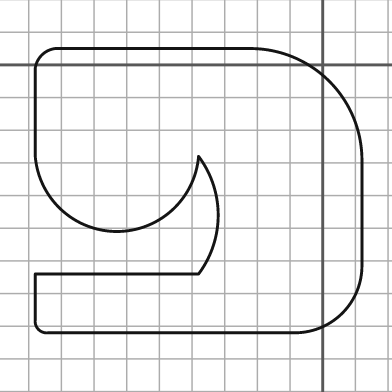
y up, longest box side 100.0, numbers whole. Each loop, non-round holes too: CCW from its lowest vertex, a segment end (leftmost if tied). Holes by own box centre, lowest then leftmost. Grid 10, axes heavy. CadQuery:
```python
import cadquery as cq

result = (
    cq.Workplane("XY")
    .moveTo(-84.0, -82.0)
    .lineTo(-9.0, -82.0)
    .threePointArc((6.0, -76.0), (12.0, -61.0))
    .lineTo(12.0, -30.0)
    .threePointArc((2.0, -5.0), (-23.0, 5.0))
    .lineTo(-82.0, 5.0)
    .threePointArc((-86.0, 3.0), (-88.0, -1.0))
    .lineTo(-88.0, -28.0)
    .threePointArc((-63.0, -51.0), (-38.0, -28.0))
    .threePointArc((-32.0, -46.0), (-38.0, -64.0))
    .lineTo(-88.0, -64.0)
    .lineTo(-88.0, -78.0)
    .threePointArc((-87.0, -81.0), (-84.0, -82.0))
    .close()
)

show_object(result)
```